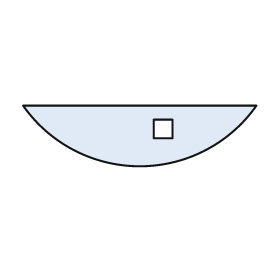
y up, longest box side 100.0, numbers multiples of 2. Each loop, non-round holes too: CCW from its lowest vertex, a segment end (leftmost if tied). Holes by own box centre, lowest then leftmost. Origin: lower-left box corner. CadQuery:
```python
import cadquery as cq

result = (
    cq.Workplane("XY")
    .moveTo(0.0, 26.0)
    .threePointArc((50.0, 0.0), (100.0, 26.0))
    .close()
    .moveTo(56.0, 12.0)
    .lineTo(64.0, 12.0)
    .lineTo(64.0, 20.0)
    .lineTo(56.0, 20.0)
    .close()
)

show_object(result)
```